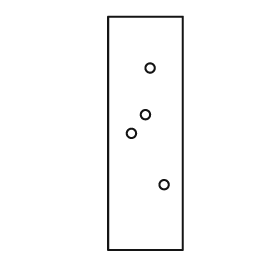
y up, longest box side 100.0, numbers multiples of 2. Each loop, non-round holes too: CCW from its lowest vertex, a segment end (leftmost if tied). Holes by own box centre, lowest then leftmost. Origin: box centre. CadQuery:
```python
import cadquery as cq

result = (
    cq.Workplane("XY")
    .moveTo(-16.0, -50.0)
    .lineTo(16.0, -50.0)
    .lineTo(16.0, 50.0)
    .lineTo(-16.0, 50.0)
    .close()
    .moveTo(8.0, -22.0)
    .circle(2.0)
    .moveTo(-6.0, 0.0)
    .circle(2.0)
    .moveTo(0.0, 8.0)
    .circle(2.0)
    .moveTo(2.0, 28.0)
    .circle(2.0)
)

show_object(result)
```